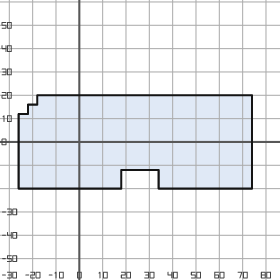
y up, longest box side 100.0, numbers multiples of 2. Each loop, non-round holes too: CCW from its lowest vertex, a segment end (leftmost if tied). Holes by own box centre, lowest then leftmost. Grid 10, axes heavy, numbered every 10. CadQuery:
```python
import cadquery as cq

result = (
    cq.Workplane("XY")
    .moveTo(-26.0, -20.0)
    .lineTo(18.0, -20.0)
    .lineTo(18.0, -12.0)
    .lineTo(34.0, -12.0)
    .lineTo(34.0, -20.0)
    .lineTo(74.0, -20.0)
    .lineTo(74.0, 20.0)
    .lineTo(-18.0, 20.0)
    .lineTo(-18.0, 16.0)
    .lineTo(-22.0, 16.0)
    .lineTo(-22.0, 12.0)
    .lineTo(-26.0, 12.0)
    .close()
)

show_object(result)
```